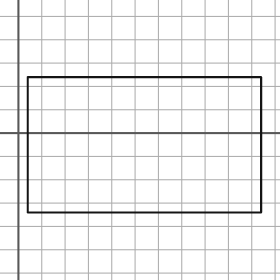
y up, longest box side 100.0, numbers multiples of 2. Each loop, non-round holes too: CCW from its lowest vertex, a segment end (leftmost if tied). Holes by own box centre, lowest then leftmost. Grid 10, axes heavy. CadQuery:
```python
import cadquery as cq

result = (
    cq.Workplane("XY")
    .moveTo(4.0, -34.0)
    .lineTo(104.0, -34.0)
    .lineTo(104.0, 24.0)
    .lineTo(4.0, 24.0)
    .close()
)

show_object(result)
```